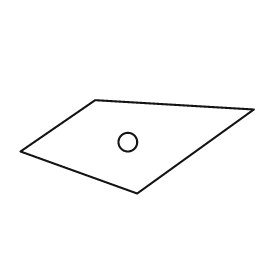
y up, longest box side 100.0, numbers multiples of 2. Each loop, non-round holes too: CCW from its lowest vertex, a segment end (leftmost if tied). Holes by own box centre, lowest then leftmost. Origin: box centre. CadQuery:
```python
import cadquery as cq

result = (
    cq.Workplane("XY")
    .moveTo(0.0, -20.0)
    .lineTo(50.0, 16.0)
    .lineTo(-18.0, 20.0)
    .lineTo(-50.0, -2.0)
    .close()
    .moveTo(-4.0, 2.0)
    .circle(4.0)
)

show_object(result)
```